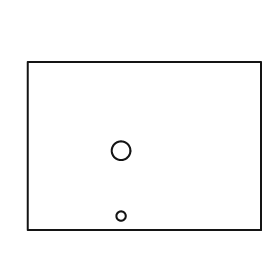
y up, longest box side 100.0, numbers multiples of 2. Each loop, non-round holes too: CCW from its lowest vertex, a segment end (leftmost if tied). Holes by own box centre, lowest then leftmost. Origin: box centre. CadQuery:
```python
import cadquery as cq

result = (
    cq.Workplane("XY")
    .moveTo(-50.0, -36.0)
    .lineTo(50.0, -36.0)
    .lineTo(50.0, 36.0)
    .lineTo(-50.0, 36.0)
    .close()
    .moveTo(-10.0, -30.0)
    .circle(2.0)
    .moveTo(-10.0, -2.0)
    .circle(4.0)
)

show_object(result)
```